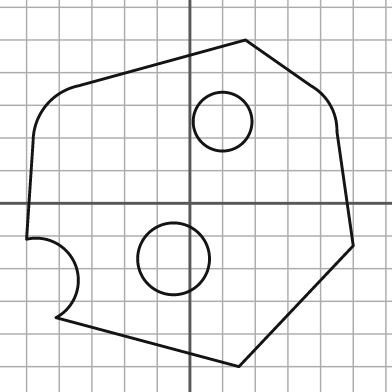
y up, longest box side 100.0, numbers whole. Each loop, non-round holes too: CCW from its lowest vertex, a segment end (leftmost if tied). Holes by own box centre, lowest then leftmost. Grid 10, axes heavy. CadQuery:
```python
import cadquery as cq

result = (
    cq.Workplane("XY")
    .moveTo(15.0, -50.0)
    .lineTo(50.0, -13.0)
    .lineTo(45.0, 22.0)
    .threePointArc((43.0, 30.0), (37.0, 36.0))
    .lineTo(17.0, 50.0)
    .lineTo(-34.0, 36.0)
    .threePointArc((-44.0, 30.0), (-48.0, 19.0))
    .lineTo(-50.0, -11.0)
    .threePointArc((-35.0, -19.0), (-41.0, -35.0))
    .close()
    .moveTo(-5.0, -17.0)
    .circle(11.0)
    .moveTo(10.0, 25.0)
    .circle(9.0)
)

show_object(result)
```